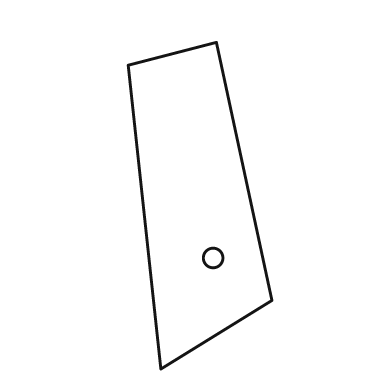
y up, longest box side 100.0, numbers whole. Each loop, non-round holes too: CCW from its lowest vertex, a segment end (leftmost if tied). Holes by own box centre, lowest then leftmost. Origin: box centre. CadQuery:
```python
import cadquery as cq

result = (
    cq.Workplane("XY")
    .moveTo(-12.0, -50.0)
    .lineTo(22.0, -29.0)
    .lineTo(5.0, 50.0)
    .lineTo(-22.0, 43.0)
    .close()
    .moveTo(4.0, -16.0)
    .circle(3.0)
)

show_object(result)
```